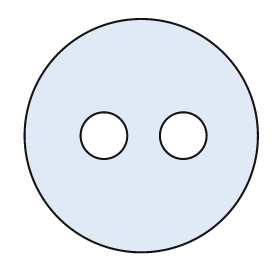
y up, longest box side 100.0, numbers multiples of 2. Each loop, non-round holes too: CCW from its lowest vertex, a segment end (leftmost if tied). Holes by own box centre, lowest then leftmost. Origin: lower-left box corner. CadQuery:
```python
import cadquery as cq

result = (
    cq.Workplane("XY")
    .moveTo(50.0, 50.0)
    .circle(50.0)
    .moveTo(34.0, 50.0)
    .circle(10.0)
    .moveTo(68.0, 50.0)
    .circle(10.0)
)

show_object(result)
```